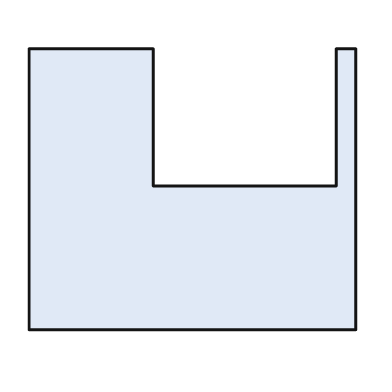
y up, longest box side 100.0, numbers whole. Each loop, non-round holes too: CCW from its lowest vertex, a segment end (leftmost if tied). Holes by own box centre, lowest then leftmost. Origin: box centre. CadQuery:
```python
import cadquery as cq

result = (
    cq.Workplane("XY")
    .moveTo(-50.0, -43.0)
    .lineTo(50.0, -43.0)
    .lineTo(50.0, 43.0)
    .lineTo(44.0, 43.0)
    .lineTo(44.0, 1.0)
    .lineTo(-12.0, 1.0)
    .lineTo(-12.0, 43.0)
    .lineTo(-50.0, 43.0)
    .close()
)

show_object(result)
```